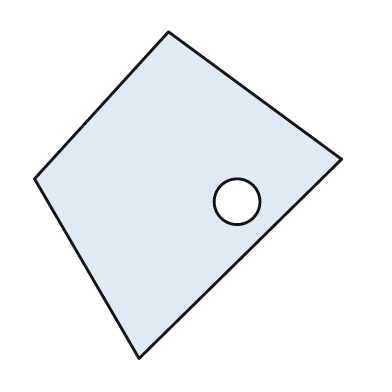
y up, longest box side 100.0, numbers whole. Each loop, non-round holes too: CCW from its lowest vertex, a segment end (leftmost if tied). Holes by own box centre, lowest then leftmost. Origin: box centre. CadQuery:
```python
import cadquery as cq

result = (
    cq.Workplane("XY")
    .moveTo(-15.0, -50.0)
    .lineTo(47.0, 11.0)
    .lineTo(-6.0, 50.0)
    .lineTo(-47.0, 5.0)
    .close()
    .moveTo(15.0, -2.0)
    .circle(7.0)
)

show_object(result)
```